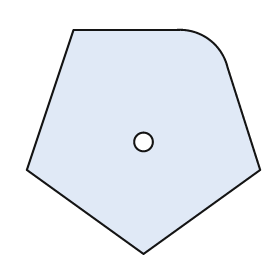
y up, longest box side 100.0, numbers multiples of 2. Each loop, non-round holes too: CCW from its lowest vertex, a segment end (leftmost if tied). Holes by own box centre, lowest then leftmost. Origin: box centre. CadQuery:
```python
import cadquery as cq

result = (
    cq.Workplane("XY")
    .moveTo(0.0, -48.0)
    .lineTo(50.0, -12.0)
    .lineTo(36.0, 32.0)
    .threePointArc((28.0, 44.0), (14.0, 48.0))
    .lineTo(-30.0, 48.0)
    .lineTo(-50.0, -12.0)
    .close()
    .moveTo(0.0, 0.0)
    .circle(4.0)
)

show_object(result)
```